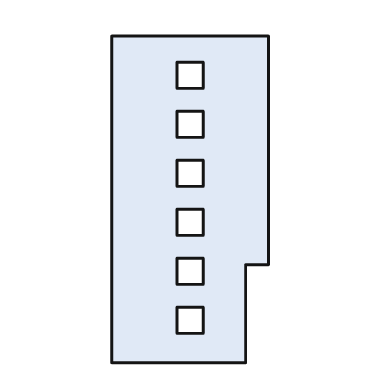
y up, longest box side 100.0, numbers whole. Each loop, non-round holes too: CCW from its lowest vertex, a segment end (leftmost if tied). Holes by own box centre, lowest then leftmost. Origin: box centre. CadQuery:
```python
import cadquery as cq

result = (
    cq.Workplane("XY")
    .moveTo(-24.0, -50.0)
    .lineTo(17.0, -50.0)
    .lineTo(17.0, -20.0)
    .lineTo(24.0, -20.0)
    .lineTo(24.0, 50.0)
    .lineTo(-24.0, 50.0)
    .close()
    .moveTo(-4.0, -41.0)
    .lineTo(4.0, -41.0)
    .lineTo(4.0, -33.0)
    .lineTo(-4.0, -33.0)
    .close()
    .moveTo(-4.0, -26.0)
    .lineTo(4.0, -26.0)
    .lineTo(4.0, -18.0)
    .lineTo(-4.0, -18.0)
    .close()
    .moveTo(-4.0, -11.0)
    .lineTo(4.0, -11.0)
    .lineTo(4.0, -3.0)
    .lineTo(-4.0, -3.0)
    .close()
    .moveTo(-4.0, 4.0)
    .lineTo(4.0, 4.0)
    .lineTo(4.0, 12.0)
    .lineTo(-4.0, 12.0)
    .close()
    .moveTo(-4.0, 19.0)
    .lineTo(4.0, 19.0)
    .lineTo(4.0, 27.0)
    .lineTo(-4.0, 27.0)
    .close()
    .moveTo(-4.0, 34.0)
    .lineTo(4.0, 34.0)
    .lineTo(4.0, 42.0)
    .lineTo(-4.0, 42.0)
    .close()
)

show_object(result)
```